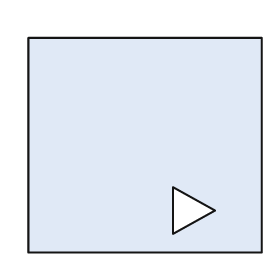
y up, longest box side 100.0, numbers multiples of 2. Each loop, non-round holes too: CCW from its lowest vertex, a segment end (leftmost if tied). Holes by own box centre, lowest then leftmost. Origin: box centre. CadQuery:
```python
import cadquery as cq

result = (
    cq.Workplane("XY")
    .moveTo(-50.0, -46.0)
    .lineTo(50.0, -46.0)
    .lineTo(50.0, 46.0)
    .lineTo(-50.0, 46.0)
    .close()
    .moveTo(12.0, -38.0)
    .lineTo(30.0, -28.0)
    .lineTo(12.0, -18.0)
    .close()
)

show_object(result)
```